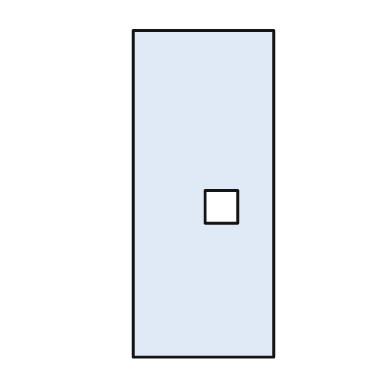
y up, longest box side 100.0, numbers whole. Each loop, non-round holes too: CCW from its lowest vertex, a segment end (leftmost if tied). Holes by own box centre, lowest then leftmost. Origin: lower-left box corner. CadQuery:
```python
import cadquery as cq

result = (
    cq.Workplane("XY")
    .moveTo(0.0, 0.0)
    .lineTo(43.0, 0.0)
    .lineTo(43.0, 100.0)
    .lineTo(0.0, 100.0)
    .close()
    .moveTo(22.0, 41.0)
    .lineTo(32.0, 41.0)
    .lineTo(32.0, 51.0)
    .lineTo(22.0, 51.0)
    .close()
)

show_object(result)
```